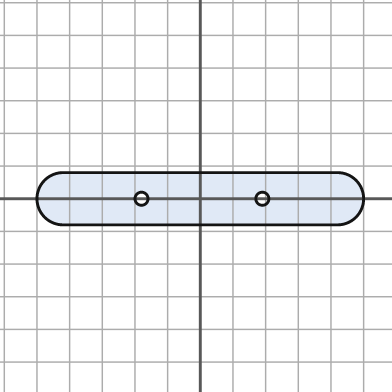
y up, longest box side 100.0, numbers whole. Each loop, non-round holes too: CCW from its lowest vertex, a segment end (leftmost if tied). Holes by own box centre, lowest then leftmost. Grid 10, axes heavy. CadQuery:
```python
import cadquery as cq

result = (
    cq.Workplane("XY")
    .moveTo(-42.0, -8.0)
    .lineTo(42.0, -8.0)
    .threePointArc((50.0, 0.0), (42.0, 8.0))
    .lineTo(-42.0, 8.0)
    .threePointArc((-50.0, 0.0), (-42.0, -8.0))
    .close()
    .moveTo(-18.0, 0.0)
    .circle(2.0)
    .moveTo(19.0, 0.0)
    .circle(2.0)
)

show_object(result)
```